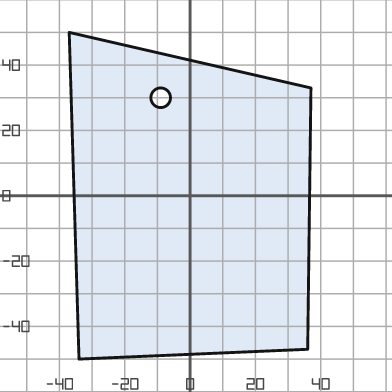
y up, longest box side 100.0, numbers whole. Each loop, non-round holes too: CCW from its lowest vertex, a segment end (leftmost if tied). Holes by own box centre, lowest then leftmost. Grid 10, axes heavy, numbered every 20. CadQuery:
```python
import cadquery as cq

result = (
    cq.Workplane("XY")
    .moveTo(-34.0, -50.0)
    .lineTo(36.0, -47.0)
    .lineTo(37.0, 33.0)
    .lineTo(-37.0, 50.0)
    .close()
    .moveTo(-9.0, 30.0)
    .circle(3.0)
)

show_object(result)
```